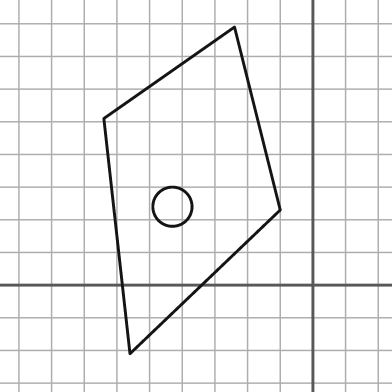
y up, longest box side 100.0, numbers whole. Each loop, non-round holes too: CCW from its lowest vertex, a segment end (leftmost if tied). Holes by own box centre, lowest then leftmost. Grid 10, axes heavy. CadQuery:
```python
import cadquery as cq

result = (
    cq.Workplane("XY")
    .moveTo(-56.0, -21.0)
    .lineTo(-10.0, 23.0)
    .lineTo(-24.0, 79.0)
    .lineTo(-64.0, 51.0)
    .close()
    .moveTo(-43.0, 24.0)
    .circle(6.0)
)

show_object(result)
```